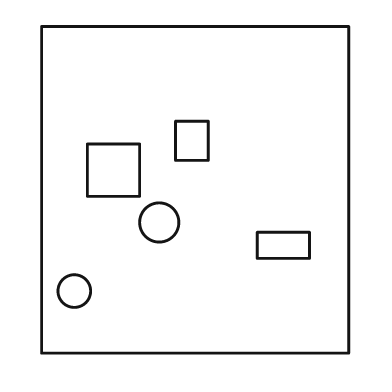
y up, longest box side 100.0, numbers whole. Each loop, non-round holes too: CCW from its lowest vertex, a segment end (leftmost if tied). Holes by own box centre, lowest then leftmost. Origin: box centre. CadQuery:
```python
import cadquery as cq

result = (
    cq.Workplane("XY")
    .moveTo(-47.0, -50.0)
    .lineTo(47.0, -50.0)
    .lineTo(47.0, 50.0)
    .lineTo(-47.0, 50.0)
    .close()
    .moveTo(-37.0, -31.0)
    .circle(5.0)
    .moveTo(19.0, -21.0)
    .lineTo(35.0, -21.0)
    .lineTo(35.0, -13.0)
    .lineTo(19.0, -13.0)
    .close()
    .moveTo(-11.0, -10.0)
    .circle(6.0)
    .moveTo(-33.0, -2.0)
    .lineTo(-17.0, -2.0)
    .lineTo(-17.0, 14.0)
    .lineTo(-33.0, 14.0)
    .close()
    .moveTo(-6.0, 9.0)
    .lineTo(4.0, 9.0)
    .lineTo(4.0, 21.0)
    .lineTo(-6.0, 21.0)
    .close()
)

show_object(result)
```